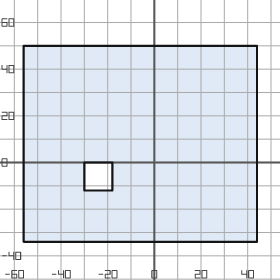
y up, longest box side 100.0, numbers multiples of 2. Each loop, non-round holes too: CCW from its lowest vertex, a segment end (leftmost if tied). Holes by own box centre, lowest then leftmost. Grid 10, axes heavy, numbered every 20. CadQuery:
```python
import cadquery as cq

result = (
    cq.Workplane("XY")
    .moveTo(-56.0, -34.0)
    .lineTo(44.0, -34.0)
    .lineTo(44.0, 50.0)
    .lineTo(-56.0, 50.0)
    .close()
    .moveTo(-30.0, -12.0)
    .lineTo(-18.0, -12.0)
    .lineTo(-18.0, 0.0)
    .lineTo(-30.0, 0.0)
    .close()
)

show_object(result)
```